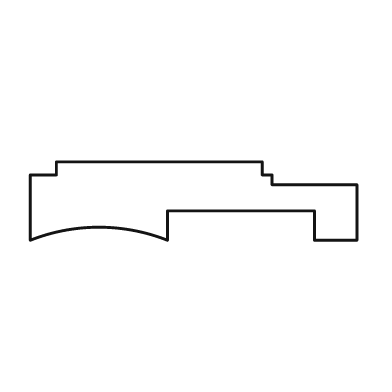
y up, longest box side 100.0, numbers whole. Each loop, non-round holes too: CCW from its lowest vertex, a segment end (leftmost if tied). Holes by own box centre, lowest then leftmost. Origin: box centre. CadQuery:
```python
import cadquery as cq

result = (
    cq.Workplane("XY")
    .moveTo(-50.0, -12.0)
    .threePointArc((-29.0, -8.0), (-8.0, -12.0))
    .lineTo(-8.0, -3.0)
    .lineTo(37.0, -3.0)
    .lineTo(37.0, -12.0)
    .lineTo(50.0, -12.0)
    .lineTo(50.0, 5.0)
    .lineTo(24.0, 5.0)
    .lineTo(24.0, 8.0)
    .lineTo(21.0, 8.0)
    .lineTo(21.0, 12.0)
    .lineTo(-42.0, 12.0)
    .lineTo(-42.0, 8.0)
    .lineTo(-50.0, 8.0)
    .close()
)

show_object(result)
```